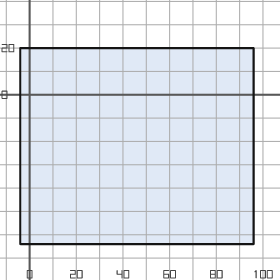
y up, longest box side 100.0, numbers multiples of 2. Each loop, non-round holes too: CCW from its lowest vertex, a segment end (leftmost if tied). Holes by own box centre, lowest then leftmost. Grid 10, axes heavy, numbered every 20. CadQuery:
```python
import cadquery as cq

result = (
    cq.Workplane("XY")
    .moveTo(-4.0, -64.0)
    .lineTo(96.0, -64.0)
    .lineTo(96.0, 20.0)
    .lineTo(-4.0, 20.0)
    .close()
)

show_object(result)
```